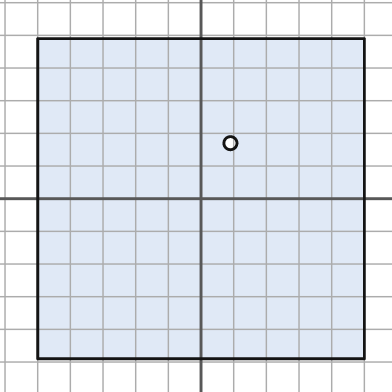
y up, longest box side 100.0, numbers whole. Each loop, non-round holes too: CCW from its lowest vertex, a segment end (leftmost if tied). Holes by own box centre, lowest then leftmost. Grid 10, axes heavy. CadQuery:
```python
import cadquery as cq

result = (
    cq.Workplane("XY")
    .moveTo(-50.0, -49.0)
    .lineTo(50.0, -49.0)
    .lineTo(50.0, 49.0)
    .lineTo(-50.0, 49.0)
    .close()
    .moveTo(9.0, 17.0)
    .circle(2.0)
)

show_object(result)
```